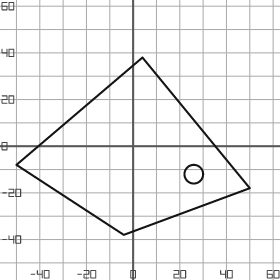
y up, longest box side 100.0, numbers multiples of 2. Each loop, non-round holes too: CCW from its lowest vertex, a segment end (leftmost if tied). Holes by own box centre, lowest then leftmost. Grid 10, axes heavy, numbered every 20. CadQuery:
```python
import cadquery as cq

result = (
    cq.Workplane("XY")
    .moveTo(-4.0, -38.0)
    .lineTo(50.0, -18.0)
    .lineTo(4.0, 38.0)
    .lineTo(-50.0, -8.0)
    .close()
    .moveTo(26.0, -12.0)
    .circle(4.0)
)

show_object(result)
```